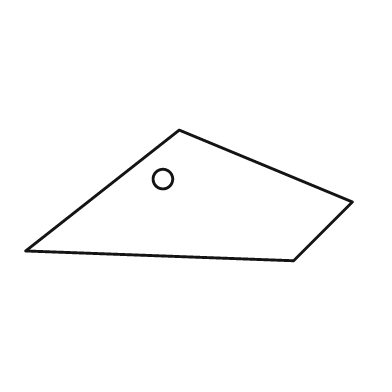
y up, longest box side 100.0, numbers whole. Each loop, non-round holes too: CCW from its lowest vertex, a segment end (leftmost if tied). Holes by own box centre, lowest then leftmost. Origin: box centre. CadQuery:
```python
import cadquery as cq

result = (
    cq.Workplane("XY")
    .moveTo(32.0, -20.0)
    .lineTo(50.0, -2.0)
    .lineTo(-3.0, 20.0)
    .lineTo(-50.0, -17.0)
    .close()
    .moveTo(-8.0, 5.0)
    .circle(3.0)
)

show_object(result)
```